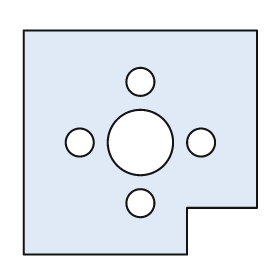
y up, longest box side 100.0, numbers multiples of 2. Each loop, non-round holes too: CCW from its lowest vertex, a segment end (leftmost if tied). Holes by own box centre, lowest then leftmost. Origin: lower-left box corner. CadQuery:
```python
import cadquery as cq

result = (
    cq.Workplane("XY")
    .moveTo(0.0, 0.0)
    .lineTo(70.0, 0.0)
    .lineTo(70.0, 20.0)
    .lineTo(100.0, 20.0)
    .lineTo(100.0, 96.0)
    .lineTo(0.0, 96.0)
    .close()
    .moveTo(50.0, 22.0)
    .circle(6.0)
    .moveTo(24.0, 48.0)
    .circle(6.0)
    .moveTo(50.0, 48.0)
    .circle(14.0)
    .moveTo(76.0, 48.0)
    .circle(6.0)
    .moveTo(50.0, 74.0)
    .circle(6.0)
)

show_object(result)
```